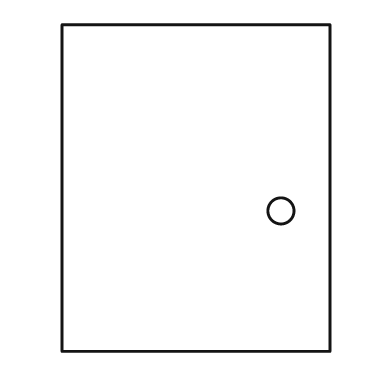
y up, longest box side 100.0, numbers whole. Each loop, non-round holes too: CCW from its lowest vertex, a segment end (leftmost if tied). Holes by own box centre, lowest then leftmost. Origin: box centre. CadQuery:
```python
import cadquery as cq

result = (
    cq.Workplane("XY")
    .moveTo(-41.0, -50.0)
    .lineTo(41.0, -50.0)
    .lineTo(41.0, 50.0)
    .lineTo(-41.0, 50.0)
    .close()
    .moveTo(26.0, -7.0)
    .circle(4.0)
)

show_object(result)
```